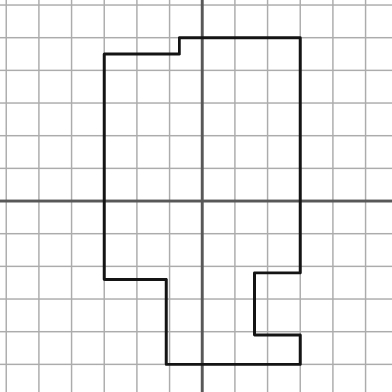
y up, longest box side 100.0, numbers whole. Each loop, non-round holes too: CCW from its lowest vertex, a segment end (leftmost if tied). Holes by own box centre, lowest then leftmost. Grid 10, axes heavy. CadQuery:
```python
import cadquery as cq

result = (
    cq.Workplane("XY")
    .moveTo(-11.0, -50.0)
    .lineTo(30.0, -50.0)
    .lineTo(30.0, -41.0)
    .lineTo(16.0, -41.0)
    .lineTo(16.0, -22.0)
    .lineTo(30.0, -22.0)
    .lineTo(30.0, 50.0)
    .lineTo(-7.0, 50.0)
    .lineTo(-7.0, 45.0)
    .lineTo(-30.0, 45.0)
    .lineTo(-30.0, -24.0)
    .lineTo(-11.0, -24.0)
    .close()
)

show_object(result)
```